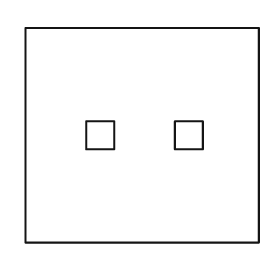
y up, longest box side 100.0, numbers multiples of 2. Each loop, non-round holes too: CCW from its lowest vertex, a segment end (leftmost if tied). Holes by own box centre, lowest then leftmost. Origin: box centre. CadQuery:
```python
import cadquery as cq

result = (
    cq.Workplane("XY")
    .moveTo(-50.0, -46.0)
    .lineTo(50.0, -46.0)
    .lineTo(50.0, 46.0)
    .lineTo(-50.0, 46.0)
    .close()
    .moveTo(-24.0, -6.0)
    .lineTo(-12.0, -6.0)
    .lineTo(-12.0, 6.0)
    .lineTo(-24.0, 6.0)
    .close()
    .moveTo(14.0, -6.0)
    .lineTo(26.0, -6.0)
    .lineTo(26.0, 6.0)
    .lineTo(14.0, 6.0)
    .close()
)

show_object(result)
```